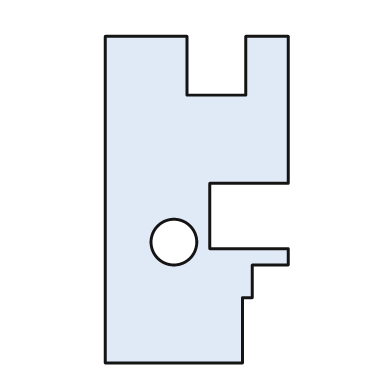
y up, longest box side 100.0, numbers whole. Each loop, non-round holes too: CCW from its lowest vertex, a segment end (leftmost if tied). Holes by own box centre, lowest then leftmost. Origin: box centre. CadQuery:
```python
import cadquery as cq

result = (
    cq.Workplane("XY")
    .moveTo(-28.0, -50.0)
    .lineTo(14.0, -50.0)
    .lineTo(14.0, -30.0)
    .lineTo(17.0, -30.0)
    .lineTo(17.0, -20.0)
    .lineTo(28.0, -20.0)
    .lineTo(28.0, -15.0)
    .lineTo(4.0, -15.0)
    .lineTo(4.0, 5.0)
    .lineTo(28.0, 5.0)
    .lineTo(28.0, 50.0)
    .lineTo(15.0, 50.0)
    .lineTo(15.0, 32.0)
    .lineTo(-3.0, 32.0)
    .lineTo(-3.0, 50.0)
    .lineTo(-28.0, 50.0)
    .close()
    .moveTo(-7.0, -13.0)
    .circle(7.0)
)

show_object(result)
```